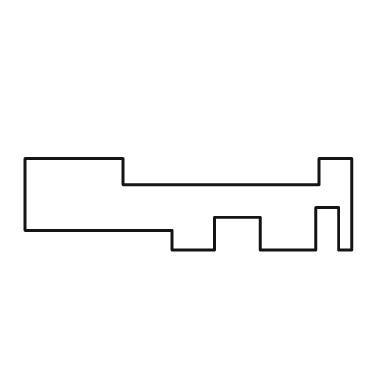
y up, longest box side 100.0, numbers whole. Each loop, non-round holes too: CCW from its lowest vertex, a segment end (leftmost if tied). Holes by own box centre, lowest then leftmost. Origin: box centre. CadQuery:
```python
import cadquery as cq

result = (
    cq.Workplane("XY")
    .moveTo(-5.0, -14.0)
    .lineTo(8.0, -14.0)
    .lineTo(8.0, -4.0)
    .lineTo(22.0, -4.0)
    .lineTo(22.0, -14.0)
    .lineTo(39.0, -14.0)
    .lineTo(39.0, -1.0)
    .lineTo(46.0, -1.0)
    .lineTo(46.0, -14.0)
    .lineTo(50.0, -14.0)
    .lineTo(50.0, 14.0)
    .lineTo(40.0, 14.0)
    .lineTo(40.0, 6.0)
    .lineTo(-20.0, 6.0)
    .lineTo(-20.0, 14.0)
    .lineTo(-50.0, 14.0)
    .lineTo(-50.0, -8.0)
    .lineTo(-5.0, -8.0)
    .close()
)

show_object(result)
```